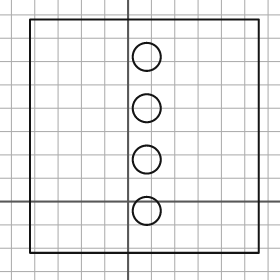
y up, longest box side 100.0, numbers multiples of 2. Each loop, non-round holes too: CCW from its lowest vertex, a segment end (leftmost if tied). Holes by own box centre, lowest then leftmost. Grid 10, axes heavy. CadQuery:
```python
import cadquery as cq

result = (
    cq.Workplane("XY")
    .moveTo(-42.0, -22.0)
    .lineTo(56.0, -22.0)
    .lineTo(56.0, 78.0)
    .lineTo(-42.0, 78.0)
    .close()
    .moveTo(8.0, -4.0)
    .circle(6.0)
    .moveTo(8.0, 18.0)
    .circle(6.0)
    .moveTo(8.0, 40.0)
    .circle(6.0)
    .moveTo(8.0, 62.0)
    .circle(6.0)
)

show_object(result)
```